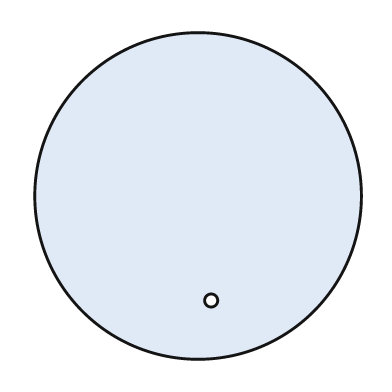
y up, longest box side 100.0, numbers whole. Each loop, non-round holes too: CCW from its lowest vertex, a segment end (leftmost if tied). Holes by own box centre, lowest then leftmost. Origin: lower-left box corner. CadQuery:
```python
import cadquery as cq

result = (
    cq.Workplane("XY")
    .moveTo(50.0, 50.0)
    .circle(50.0)
    .moveTo(54.0, 18.0)
    .circle(2.0)
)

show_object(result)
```